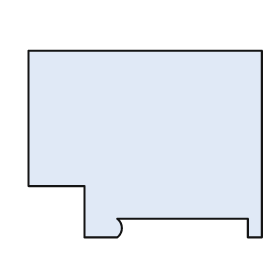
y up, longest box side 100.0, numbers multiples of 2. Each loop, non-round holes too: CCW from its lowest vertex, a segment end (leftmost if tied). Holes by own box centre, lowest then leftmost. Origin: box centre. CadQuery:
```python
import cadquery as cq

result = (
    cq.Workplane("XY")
    .moveTo(-26.0, -40.0)
    .lineTo(-12.0, -40.0)
    .threePointArc((-10.0, -36.0), (-12.0, -32.0))
    .lineTo(44.0, -32.0)
    .lineTo(44.0, -40.0)
    .lineTo(50.0, -40.0)
    .lineTo(50.0, 40.0)
    .lineTo(-50.0, 40.0)
    .lineTo(-50.0, -18.0)
    .lineTo(-26.0, -18.0)
    .close()
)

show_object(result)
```